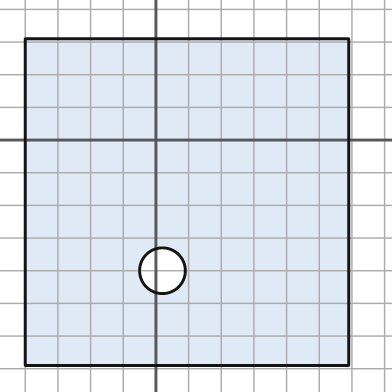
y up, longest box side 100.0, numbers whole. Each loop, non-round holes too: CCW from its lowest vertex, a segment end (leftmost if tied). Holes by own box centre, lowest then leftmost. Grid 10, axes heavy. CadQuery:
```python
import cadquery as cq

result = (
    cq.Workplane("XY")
    .moveTo(-40.0, -69.0)
    .lineTo(59.0, -69.0)
    .lineTo(59.0, 31.0)
    .lineTo(-40.0, 31.0)
    .close()
    .moveTo(2.0, -40.0)
    .circle(7.0)
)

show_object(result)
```